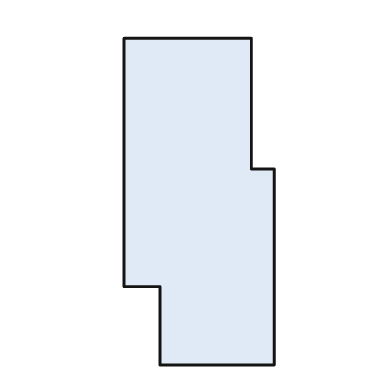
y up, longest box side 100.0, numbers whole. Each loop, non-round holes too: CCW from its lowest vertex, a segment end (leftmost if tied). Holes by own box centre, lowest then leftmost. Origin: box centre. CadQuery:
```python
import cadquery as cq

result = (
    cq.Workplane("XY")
    .moveTo(-12.0, -50.0)
    .lineTo(23.0, -50.0)
    .lineTo(23.0, 10.0)
    .lineTo(16.0, 10.0)
    .lineTo(16.0, 50.0)
    .lineTo(-23.0, 50.0)
    .lineTo(-23.0, -26.0)
    .lineTo(-12.0, -26.0)
    .close()
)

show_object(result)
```